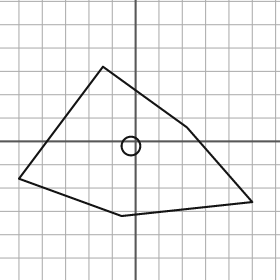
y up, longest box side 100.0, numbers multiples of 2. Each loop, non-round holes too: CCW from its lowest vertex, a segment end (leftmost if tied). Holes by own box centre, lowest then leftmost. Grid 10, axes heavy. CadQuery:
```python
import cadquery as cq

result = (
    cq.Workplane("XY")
    .moveTo(-6.0, -32.0)
    .lineTo(50.0, -26.0)
    .lineTo(22.0, 6.0)
    .lineTo(-14.0, 32.0)
    .lineTo(-50.0, -16.0)
    .close()
    .moveTo(-2.0, -2.0)
    .circle(4.0)
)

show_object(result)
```